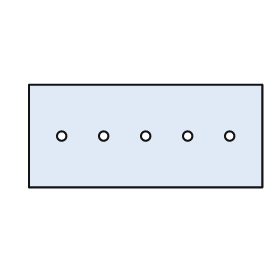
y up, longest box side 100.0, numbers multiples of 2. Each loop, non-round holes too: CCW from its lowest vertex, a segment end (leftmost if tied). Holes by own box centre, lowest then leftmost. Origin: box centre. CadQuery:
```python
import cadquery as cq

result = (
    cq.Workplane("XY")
    .moveTo(-50.0, -22.0)
    .lineTo(50.0, -22.0)
    .lineTo(50.0, 22.0)
    .lineTo(-50.0, 22.0)
    .close()
    .moveTo(-36.0, 0.0)
    .circle(2.0)
    .moveTo(-18.0, 0.0)
    .circle(2.0)
    .moveTo(0.0, 0.0)
    .circle(2.0)
    .moveTo(18.0, 0.0)
    .circle(2.0)
    .moveTo(36.0, 0.0)
    .circle(2.0)
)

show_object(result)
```